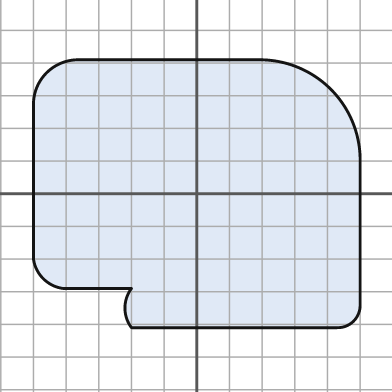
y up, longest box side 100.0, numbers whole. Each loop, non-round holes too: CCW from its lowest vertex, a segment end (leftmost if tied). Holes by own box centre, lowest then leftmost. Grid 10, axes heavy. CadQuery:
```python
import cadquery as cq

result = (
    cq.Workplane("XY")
    .moveTo(-20.0, -41.0)
    .lineTo(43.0, -41.0)
    .threePointArc((48.0, -39.0), (50.0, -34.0))
    .lineTo(50.0, 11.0)
    .threePointArc((41.0, 32.0), (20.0, 41.0))
    .lineTo(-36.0, 41.0)
    .threePointArc((-46.0, 37.0), (-50.0, 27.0))
    .lineTo(-50.0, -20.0)
    .threePointArc((-47.0, -26.0), (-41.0, -29.0))
    .lineTo(-20.0, -29.0)
    .threePointArc((-22.0, -35.0), (-20.0, -41.0))
    .close()
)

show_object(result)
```